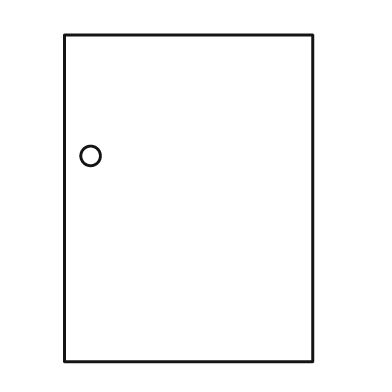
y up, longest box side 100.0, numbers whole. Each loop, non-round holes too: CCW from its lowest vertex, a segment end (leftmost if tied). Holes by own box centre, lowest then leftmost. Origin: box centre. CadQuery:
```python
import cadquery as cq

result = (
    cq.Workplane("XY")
    .moveTo(-38.0, -50.0)
    .lineTo(38.0, -50.0)
    .lineTo(38.0, 50.0)
    .lineTo(-38.0, 50.0)
    .close()
    .moveTo(-30.0, 13.0)
    .circle(3.0)
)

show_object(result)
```